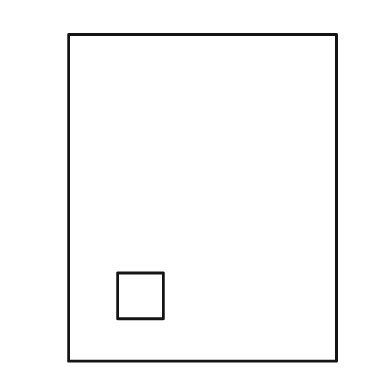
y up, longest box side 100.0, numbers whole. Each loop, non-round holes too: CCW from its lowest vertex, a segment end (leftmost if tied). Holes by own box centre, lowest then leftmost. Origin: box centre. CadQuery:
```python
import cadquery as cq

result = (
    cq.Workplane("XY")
    .moveTo(-41.0, -50.0)
    .lineTo(41.0, -50.0)
    .lineTo(41.0, 50.0)
    .lineTo(-41.0, 50.0)
    .close()
    .moveTo(-26.0, -37.0)
    .lineTo(-12.0, -37.0)
    .lineTo(-12.0, -23.0)
    .lineTo(-26.0, -23.0)
    .close()
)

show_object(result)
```